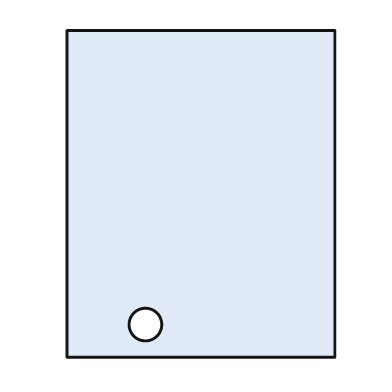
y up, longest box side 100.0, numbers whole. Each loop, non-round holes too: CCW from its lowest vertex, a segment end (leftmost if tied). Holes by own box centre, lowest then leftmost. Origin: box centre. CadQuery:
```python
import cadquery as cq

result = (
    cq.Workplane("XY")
    .moveTo(-41.0, -50.0)
    .lineTo(41.0, -50.0)
    .lineTo(41.0, 50.0)
    .lineTo(-41.0, 50.0)
    .close()
    .moveTo(-17.0, -40.0)
    .circle(5.0)
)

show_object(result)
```